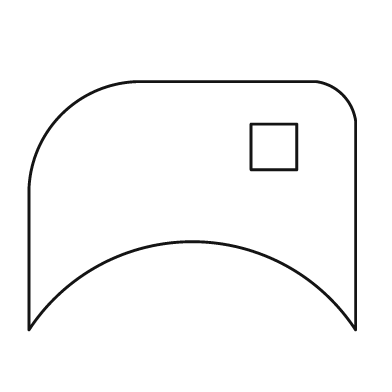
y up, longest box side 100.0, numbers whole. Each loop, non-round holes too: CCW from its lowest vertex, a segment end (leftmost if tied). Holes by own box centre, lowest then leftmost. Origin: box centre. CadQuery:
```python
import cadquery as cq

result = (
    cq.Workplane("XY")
    .moveTo(-50.0, -38.0)
    .threePointArc((0.0, -11.0), (50.0, -38.0))
    .lineTo(50.0, 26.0)
    .threePointArc((46.0, 34.0), (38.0, 38.0))
    .lineTo(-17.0, 38.0)
    .threePointArc((-40.0, 28.0), (-50.0, 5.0))
    .close()
    .moveTo(18.0, 11.0)
    .lineTo(32.0, 11.0)
    .lineTo(32.0, 25.0)
    .lineTo(18.0, 25.0)
    .close()
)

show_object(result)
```